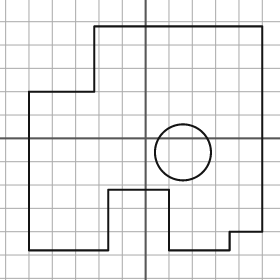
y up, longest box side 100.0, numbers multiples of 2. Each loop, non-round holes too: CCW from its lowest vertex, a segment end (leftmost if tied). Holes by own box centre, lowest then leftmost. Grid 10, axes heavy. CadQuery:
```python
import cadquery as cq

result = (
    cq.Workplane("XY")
    .moveTo(-50.0, -48.0)
    .lineTo(-16.0, -48.0)
    .lineTo(-16.0, -22.0)
    .lineTo(10.0, -22.0)
    .lineTo(10.0, -48.0)
    .lineTo(36.0, -48.0)
    .lineTo(36.0, -40.0)
    .lineTo(50.0, -40.0)
    .lineTo(50.0, 48.0)
    .lineTo(-22.0, 48.0)
    .lineTo(-22.0, 20.0)
    .lineTo(-50.0, 20.0)
    .close()
    .moveTo(16.0, -6.0)
    .circle(12.0)
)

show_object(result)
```